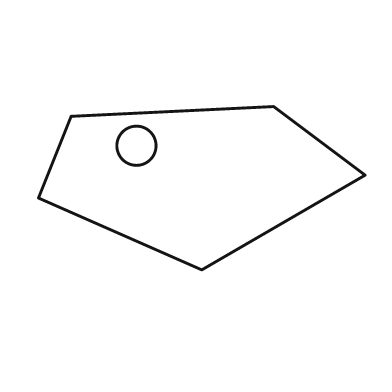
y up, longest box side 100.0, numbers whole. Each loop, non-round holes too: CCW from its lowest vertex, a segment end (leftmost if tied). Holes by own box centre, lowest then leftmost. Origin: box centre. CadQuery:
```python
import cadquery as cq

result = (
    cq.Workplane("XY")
    .moveTo(0.0, -25.0)
    .lineTo(50.0, 4.0)
    .lineTo(22.0, 25.0)
    .lineTo(-40.0, 22.0)
    .lineTo(-50.0, -3.0)
    .close()
    .moveTo(-20.0, 13.0)
    .circle(6.0)
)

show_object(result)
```